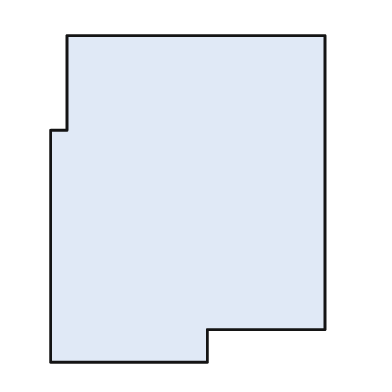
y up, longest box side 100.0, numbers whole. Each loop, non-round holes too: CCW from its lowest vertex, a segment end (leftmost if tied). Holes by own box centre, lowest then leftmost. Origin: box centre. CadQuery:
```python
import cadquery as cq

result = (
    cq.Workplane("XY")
    .moveTo(-42.0, -50.0)
    .lineTo(6.0, -50.0)
    .lineTo(6.0, -40.0)
    .lineTo(42.0, -40.0)
    .lineTo(42.0, 50.0)
    .lineTo(-37.0, 50.0)
    .lineTo(-37.0, 21.0)
    .lineTo(-42.0, 21.0)
    .close()
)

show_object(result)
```